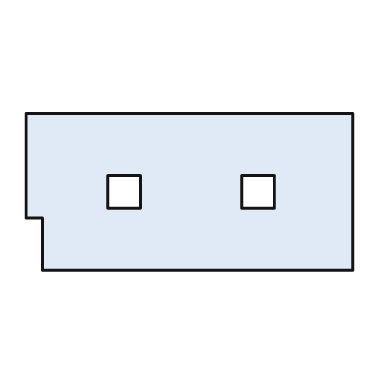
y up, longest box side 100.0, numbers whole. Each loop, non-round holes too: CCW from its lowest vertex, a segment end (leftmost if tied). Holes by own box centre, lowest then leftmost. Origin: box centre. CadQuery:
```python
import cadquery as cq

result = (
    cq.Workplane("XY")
    .moveTo(-45.0, -24.0)
    .lineTo(50.0, -24.0)
    .lineTo(50.0, 24.0)
    .lineTo(-50.0, 24.0)
    .lineTo(-50.0, -8.0)
    .lineTo(-45.0, -8.0)
    .close()
    .moveTo(-25.0, -5.0)
    .lineTo(-15.0, -5.0)
    .lineTo(-15.0, 5.0)
    .lineTo(-25.0, 5.0)
    .close()
    .moveTo(16.0, -5.0)
    .lineTo(26.0, -5.0)
    .lineTo(26.0, 5.0)
    .lineTo(16.0, 5.0)
    .close()
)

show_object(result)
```